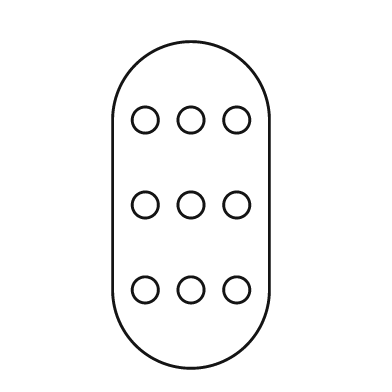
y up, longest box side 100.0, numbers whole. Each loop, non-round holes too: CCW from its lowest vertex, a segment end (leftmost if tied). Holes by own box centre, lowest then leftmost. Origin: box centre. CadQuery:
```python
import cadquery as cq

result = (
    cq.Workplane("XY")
    .moveTo(-24.0, -26.0)
    .threePointArc((0.0, -50.0), (24.0, -26.0))
    .lineTo(24.0, 26.0)
    .threePointArc((0.0, 50.0), (-24.0, 26.0))
    .close()
    .moveTo(-14.0, -26.0)
    .circle(4.0)
    .moveTo(0.0, -26.0)
    .circle(4.0)
    .moveTo(14.0, -26.0)
    .circle(4.0)
    .moveTo(-14.0, 0.0)
    .circle(4.0)
    .moveTo(0.0, 0.0)
    .circle(4.0)
    .moveTo(14.0, 0.0)
    .circle(4.0)
    .moveTo(-14.0, 26.0)
    .circle(4.0)
    .moveTo(0.0, 26.0)
    .circle(4.0)
    .moveTo(14.0, 26.0)
    .circle(4.0)
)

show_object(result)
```